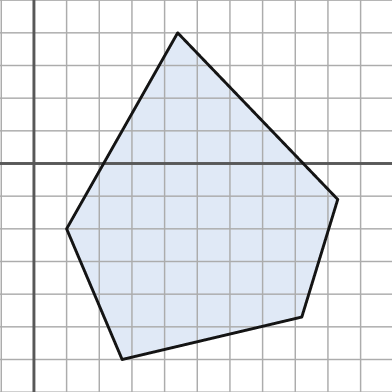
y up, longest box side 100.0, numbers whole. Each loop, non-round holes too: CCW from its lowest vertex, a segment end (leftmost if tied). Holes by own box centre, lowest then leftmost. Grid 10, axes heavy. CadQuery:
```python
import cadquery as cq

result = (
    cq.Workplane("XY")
    .moveTo(27.0, -60.0)
    .lineTo(82.0, -47.0)
    .lineTo(93.0, -11.0)
    .lineTo(44.0, 40.0)
    .lineTo(10.0, -20.0)
    .close()
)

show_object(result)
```